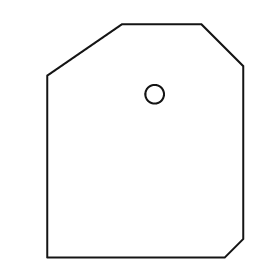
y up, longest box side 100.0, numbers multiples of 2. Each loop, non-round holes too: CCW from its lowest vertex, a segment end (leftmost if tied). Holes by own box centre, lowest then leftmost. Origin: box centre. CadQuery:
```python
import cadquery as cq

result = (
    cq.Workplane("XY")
    .moveTo(-42.0, -50.0)
    .lineTo(34.0, -50.0)
    .lineTo(42.0, -42.0)
    .lineTo(42.0, 32.0)
    .lineTo(24.0, 50.0)
    .lineTo(-10.0, 50.0)
    .lineTo(-42.0, 28.0)
    .close()
    .moveTo(4.0, 20.0)
    .circle(4.0)
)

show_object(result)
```